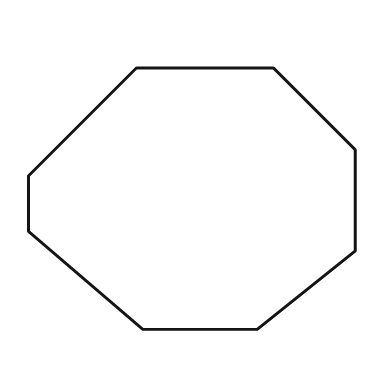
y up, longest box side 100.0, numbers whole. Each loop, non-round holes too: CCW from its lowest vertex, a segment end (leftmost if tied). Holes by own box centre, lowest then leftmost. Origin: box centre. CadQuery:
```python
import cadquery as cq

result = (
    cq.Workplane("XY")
    .moveTo(-15.0, -40.0)
    .lineTo(20.0, -40.0)
    .lineTo(50.0, -16.0)
    .lineTo(50.0, 15.0)
    .lineTo(25.0, 40.0)
    .lineTo(-17.0, 40.0)
    .lineTo(-50.0, 7.0)
    .lineTo(-50.0, -10.0)
    .close()
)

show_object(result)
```